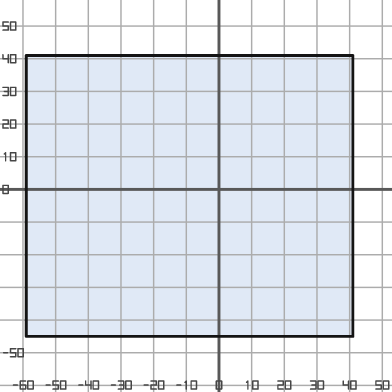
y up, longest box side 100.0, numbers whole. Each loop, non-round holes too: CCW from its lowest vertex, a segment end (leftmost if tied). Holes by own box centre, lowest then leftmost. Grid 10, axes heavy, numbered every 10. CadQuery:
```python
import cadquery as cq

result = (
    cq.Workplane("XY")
    .moveTo(-59.0, -45.0)
    .lineTo(41.0, -45.0)
    .lineTo(41.0, 41.0)
    .lineTo(-59.0, 41.0)
    .close()
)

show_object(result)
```